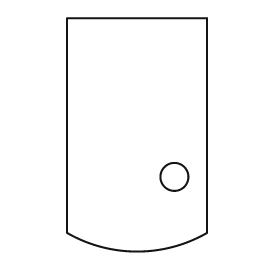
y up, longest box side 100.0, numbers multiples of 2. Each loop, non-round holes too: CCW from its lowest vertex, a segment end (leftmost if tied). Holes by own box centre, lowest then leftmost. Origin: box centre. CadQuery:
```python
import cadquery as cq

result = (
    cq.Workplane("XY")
    .moveTo(-30.0, -42.0)
    .threePointArc((0.0, -50.0), (30.0, -42.0))
    .lineTo(30.0, 50.0)
    .lineTo(-30.0, 50.0)
    .close()
    .moveTo(16.0, -18.0)
    .circle(6.0)
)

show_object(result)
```